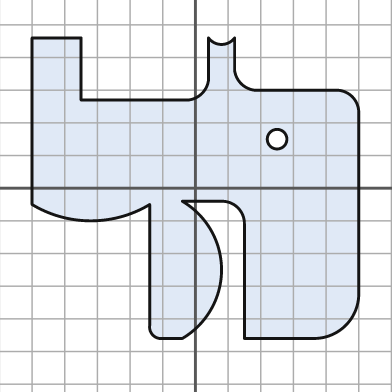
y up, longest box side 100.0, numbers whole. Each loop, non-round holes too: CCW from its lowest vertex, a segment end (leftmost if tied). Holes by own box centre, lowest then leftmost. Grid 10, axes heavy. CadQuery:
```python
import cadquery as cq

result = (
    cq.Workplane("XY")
    .moveTo(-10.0, -46.0)
    .lineTo(-4.0, -46.0)
    .threePointArc((8.0, -25.0), (-4.0, -4.0))
    .lineTo(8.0, -4.0)
    .threePointArc((13.0, -6.0), (15.0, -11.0))
    .lineTo(15.0, -46.0)
    .lineTo(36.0, -46.0)
    .threePointArc((46.0, -42.0), (50.0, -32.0))
    .lineTo(50.0, 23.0)
    .threePointArc((48.0, 28.0), (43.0, 30.0))
    .lineTo(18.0, 30.0)
    .threePointArc((14.0, 32.0), (12.0, 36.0))
    .lineTo(12.0, 46.0)
    .threePointArc((8.0, 44.0), (4.0, 46.0))
    .lineTo(4.0, 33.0)
    .threePointArc((2.0, 29.0), (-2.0, 27.0))
    .lineTo(-35.0, 27.0)
    .lineTo(-35.0, 46.0)
    .lineTo(-50.0, 46.0)
    .lineTo(-50.0, -5.0)
    .threePointArc((-32.0, -10.0), (-14.0, -5.0))
    .lineTo(-14.0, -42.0)
    .threePointArc((-13.0, -45.0), (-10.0, -46.0))
    .close()
    .moveTo(25.0, 15.0)
    .circle(3.0)
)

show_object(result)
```